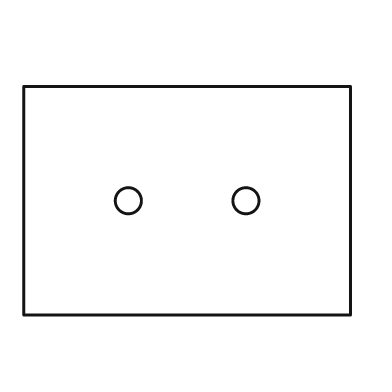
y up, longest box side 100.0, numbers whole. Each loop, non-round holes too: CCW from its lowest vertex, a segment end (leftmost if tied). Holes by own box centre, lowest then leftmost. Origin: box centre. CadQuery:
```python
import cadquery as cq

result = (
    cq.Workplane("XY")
    .moveTo(-50.0, -35.0)
    .lineTo(50.0, -35.0)
    .lineTo(50.0, 35.0)
    .lineTo(-50.0, 35.0)
    .close()
    .moveTo(-18.0, 0.0)
    .circle(4.0)
    .moveTo(18.0, 0.0)
    .circle(4.0)
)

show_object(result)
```